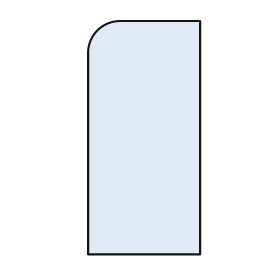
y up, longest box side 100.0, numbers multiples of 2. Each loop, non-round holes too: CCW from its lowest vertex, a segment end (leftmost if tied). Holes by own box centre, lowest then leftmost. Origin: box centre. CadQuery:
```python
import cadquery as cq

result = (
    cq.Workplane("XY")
    .moveTo(-24.0, -50.0)
    .lineTo(24.0, -50.0)
    .lineTo(24.0, 50.0)
    .lineTo(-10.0, 50.0)
    .threePointArc((-20.0, 46.0), (-24.0, 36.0))
    .close()
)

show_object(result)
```